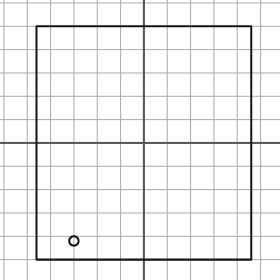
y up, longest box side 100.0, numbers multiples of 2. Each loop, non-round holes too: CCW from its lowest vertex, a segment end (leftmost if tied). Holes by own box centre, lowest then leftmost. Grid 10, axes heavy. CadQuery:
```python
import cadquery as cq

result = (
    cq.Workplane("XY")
    .moveTo(-46.0, -50.0)
    .lineTo(46.0, -50.0)
    .lineTo(46.0, 50.0)
    .lineTo(-46.0, 50.0)
    .close()
    .moveTo(-30.0, -42.0)
    .circle(2.0)
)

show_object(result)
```